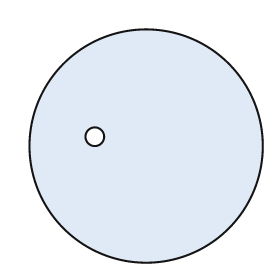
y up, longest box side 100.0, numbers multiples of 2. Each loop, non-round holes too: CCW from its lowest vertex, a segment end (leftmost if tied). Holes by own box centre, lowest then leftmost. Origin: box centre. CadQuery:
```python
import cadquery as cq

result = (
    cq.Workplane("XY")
    .moveTo(0.0, 0.0)
    .circle(50.0)
    .moveTo(-22.0, 4.0)
    .circle(4.0)
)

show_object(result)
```